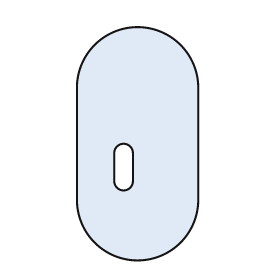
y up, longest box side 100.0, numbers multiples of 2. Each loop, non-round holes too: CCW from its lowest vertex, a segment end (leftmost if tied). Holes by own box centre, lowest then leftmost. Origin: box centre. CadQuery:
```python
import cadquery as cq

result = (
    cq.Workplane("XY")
    .moveTo(-26.0, -24.0)
    .threePointArc((0.0, -50.0), (26.0, -24.0))
    .lineTo(26.0, 24.0)
    .threePointArc((0.0, 50.0), (-26.0, 24.0))
    .close()
    .moveTo(-10.0, -16.0)
    .threePointArc((-6.0, -20.0), (-2.0, -16.0))
    .lineTo(-2.0, -4.0)
    .threePointArc((-6.0, 0.0), (-10.0, -4.0))
    .close()
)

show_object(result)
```